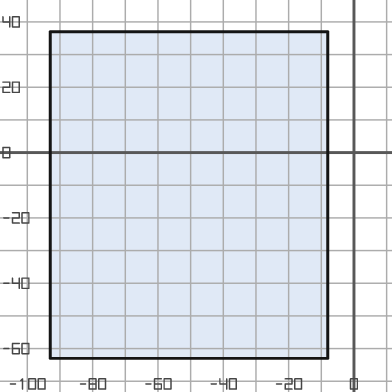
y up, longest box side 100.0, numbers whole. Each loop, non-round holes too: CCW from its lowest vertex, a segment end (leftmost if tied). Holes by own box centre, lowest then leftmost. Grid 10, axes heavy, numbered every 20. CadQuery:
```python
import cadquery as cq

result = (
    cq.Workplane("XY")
    .moveTo(-93.0, -63.0)
    .lineTo(-8.0, -63.0)
    .lineTo(-8.0, 37.0)
    .lineTo(-93.0, 37.0)
    .close()
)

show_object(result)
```